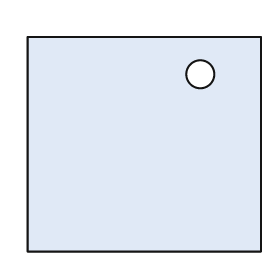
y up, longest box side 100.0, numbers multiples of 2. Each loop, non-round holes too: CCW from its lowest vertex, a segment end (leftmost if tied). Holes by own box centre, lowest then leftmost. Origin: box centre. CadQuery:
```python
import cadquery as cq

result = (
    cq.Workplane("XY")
    .moveTo(-50.0, -46.0)
    .lineTo(50.0, -46.0)
    .lineTo(50.0, 46.0)
    .lineTo(-50.0, 46.0)
    .close()
    .moveTo(24.0, 30.0)
    .circle(6.0)
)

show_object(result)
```